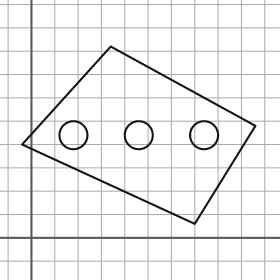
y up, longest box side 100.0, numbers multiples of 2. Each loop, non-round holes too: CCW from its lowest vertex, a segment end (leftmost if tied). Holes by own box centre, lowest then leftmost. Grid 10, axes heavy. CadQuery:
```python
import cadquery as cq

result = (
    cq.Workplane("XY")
    .moveTo(70.0, 6.0)
    .lineTo(96.0, 48.0)
    .lineTo(34.0, 82.0)
    .lineTo(-4.0, 40.0)
    .close()
    .moveTo(18.0, 44.0)
    .circle(6.0)
    .moveTo(46.0, 44.0)
    .circle(6.0)
    .moveTo(74.0, 44.0)
    .circle(6.0)
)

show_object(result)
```